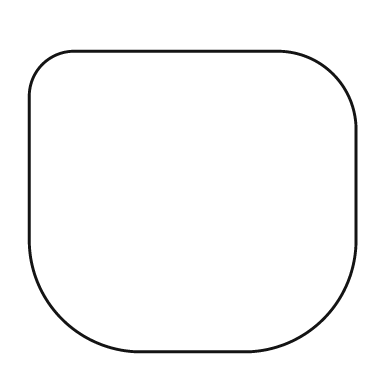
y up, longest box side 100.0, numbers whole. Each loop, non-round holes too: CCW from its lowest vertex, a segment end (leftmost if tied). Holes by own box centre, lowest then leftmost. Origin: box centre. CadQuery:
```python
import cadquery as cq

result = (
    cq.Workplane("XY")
    .moveTo(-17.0, -46.0)
    .lineTo(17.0, -46.0)
    .threePointArc((40.0, -36.0), (50.0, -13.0))
    .lineTo(50.0, 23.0)
    .threePointArc((43.0, 39.0), (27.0, 46.0))
    .lineTo(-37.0, 46.0)
    .threePointArc((-46.0, 42.0), (-50.0, 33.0))
    .lineTo(-50.0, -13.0)
    .threePointArc((-40.0, -36.0), (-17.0, -46.0))
    .close()
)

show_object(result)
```